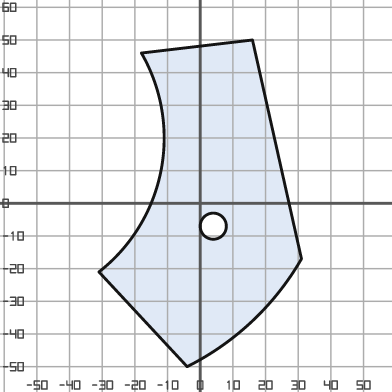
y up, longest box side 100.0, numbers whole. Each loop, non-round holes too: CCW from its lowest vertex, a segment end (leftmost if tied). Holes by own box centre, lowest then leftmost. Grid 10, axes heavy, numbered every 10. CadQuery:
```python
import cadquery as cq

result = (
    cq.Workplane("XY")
    .moveTo(-4.0, -50.0)
    .threePointArc((16.0, -36.0), (31.0, -17.0))
    .lineTo(16.0, 50.0)
    .lineTo(-18.0, 46.0)
    .threePointArc((-12.0, 10.0), (-31.0, -21.0))
    .close()
    .moveTo(4.0, -7.0)
    .circle(4.0)
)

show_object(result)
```